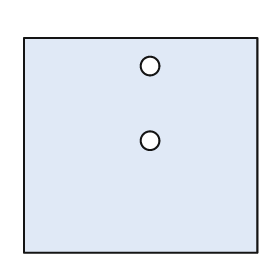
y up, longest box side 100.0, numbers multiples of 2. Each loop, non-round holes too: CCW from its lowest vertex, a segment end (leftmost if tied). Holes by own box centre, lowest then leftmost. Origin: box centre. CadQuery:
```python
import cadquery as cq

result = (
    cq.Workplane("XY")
    .moveTo(-50.0, -46.0)
    .lineTo(50.0, -46.0)
    .lineTo(50.0, 46.0)
    .lineTo(-50.0, 46.0)
    .close()
    .moveTo(4.0, 2.0)
    .circle(4.0)
    .moveTo(4.0, 34.0)
    .circle(4.0)
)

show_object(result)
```